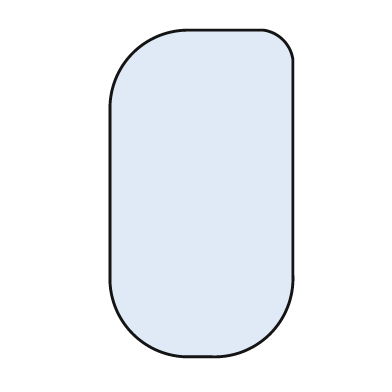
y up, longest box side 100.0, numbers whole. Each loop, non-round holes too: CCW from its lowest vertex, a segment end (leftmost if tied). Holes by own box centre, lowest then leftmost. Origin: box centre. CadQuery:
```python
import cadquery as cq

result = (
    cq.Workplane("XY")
    .moveTo(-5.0, -50.0)
    .lineTo(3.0, -50.0)
    .threePointArc((21.0, -43.0), (28.0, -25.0))
    .lineTo(28.0, 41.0)
    .threePointArc((25.0, 47.0), (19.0, 50.0))
    .lineTo(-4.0, 50.0)
    .threePointArc((-21.0, 43.0), (-28.0, 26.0))
    .lineTo(-28.0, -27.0)
    .threePointArc((-21.0, -43.0), (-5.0, -50.0))
    .close()
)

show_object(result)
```